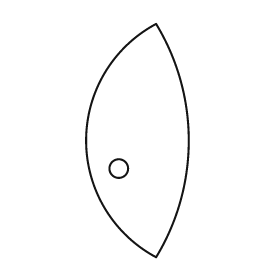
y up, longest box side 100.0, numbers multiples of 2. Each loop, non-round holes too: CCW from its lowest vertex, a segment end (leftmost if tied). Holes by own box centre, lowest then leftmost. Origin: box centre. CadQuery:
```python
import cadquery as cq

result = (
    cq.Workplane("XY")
    .moveTo(8.0, -50.0)
    .threePointArc((22.0, 0.0), (8.0, 50.0))
    .threePointArc((-22.0, 0.0), (8.0, -50.0))
    .close()
    .moveTo(-8.0, -12.0)
    .circle(4.0)
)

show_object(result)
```